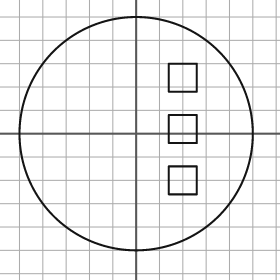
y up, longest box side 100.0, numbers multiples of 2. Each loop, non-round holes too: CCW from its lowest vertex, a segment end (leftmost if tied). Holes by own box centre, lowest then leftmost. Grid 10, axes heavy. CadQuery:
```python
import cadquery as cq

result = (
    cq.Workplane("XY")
    .moveTo(0.0, 0.0)
    .circle(50.0)
    .moveTo(14.0, -26.0)
    .lineTo(26.0, -26.0)
    .lineTo(26.0, -14.0)
    .lineTo(14.0, -14.0)
    .close()
    .moveTo(14.0, -4.0)
    .lineTo(26.0, -4.0)
    .lineTo(26.0, 8.0)
    .lineTo(14.0, 8.0)
    .close()
    .moveTo(14.0, 18.0)
    .lineTo(26.0, 18.0)
    .lineTo(26.0, 30.0)
    .lineTo(14.0, 30.0)
    .close()
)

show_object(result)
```